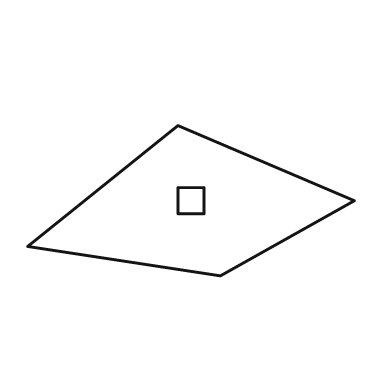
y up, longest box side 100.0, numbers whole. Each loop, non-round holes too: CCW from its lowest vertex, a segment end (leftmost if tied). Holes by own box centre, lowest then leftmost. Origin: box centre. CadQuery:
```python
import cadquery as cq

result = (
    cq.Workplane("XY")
    .moveTo(9.0, -23.0)
    .lineTo(50.0, 0.0)
    .lineTo(-4.0, 23.0)
    .lineTo(-50.0, -14.0)
    .close()
    .moveTo(-4.0, -4.0)
    .lineTo(4.0, -4.0)
    .lineTo(4.0, 4.0)
    .lineTo(-4.0, 4.0)
    .close()
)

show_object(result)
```